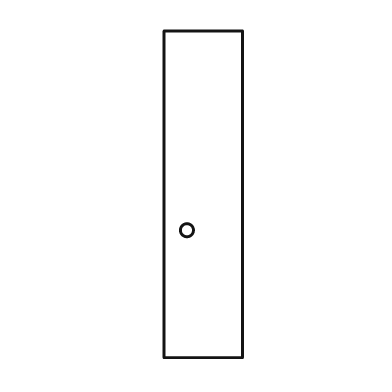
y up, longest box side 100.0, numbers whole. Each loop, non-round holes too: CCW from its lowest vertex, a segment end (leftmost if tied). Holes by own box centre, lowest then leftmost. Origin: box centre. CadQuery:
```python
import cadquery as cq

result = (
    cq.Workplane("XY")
    .moveTo(-12.0, -50.0)
    .lineTo(12.0, -50.0)
    .lineTo(12.0, 50.0)
    .lineTo(-12.0, 50.0)
    .close()
    .moveTo(-5.0, -11.0)
    .circle(2.0)
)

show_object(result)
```